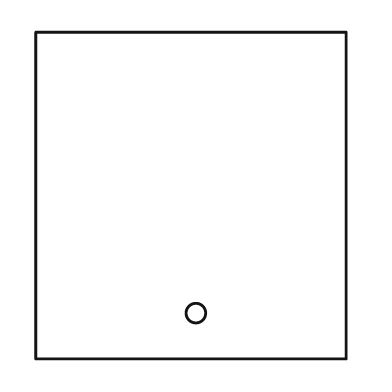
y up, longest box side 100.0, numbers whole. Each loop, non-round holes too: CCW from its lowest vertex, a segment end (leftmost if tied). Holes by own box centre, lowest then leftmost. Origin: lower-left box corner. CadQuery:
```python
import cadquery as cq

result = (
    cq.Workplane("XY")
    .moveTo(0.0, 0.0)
    .lineTo(95.0, 0.0)
    .lineTo(95.0, 100.0)
    .lineTo(0.0, 100.0)
    .close()
    .moveTo(49.0, 14.0)
    .circle(3.0)
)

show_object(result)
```